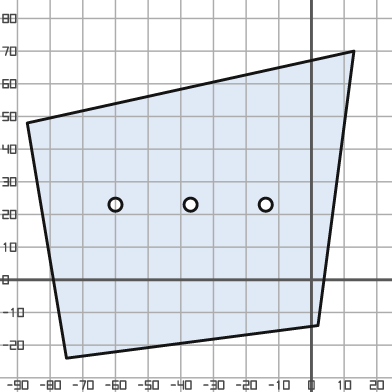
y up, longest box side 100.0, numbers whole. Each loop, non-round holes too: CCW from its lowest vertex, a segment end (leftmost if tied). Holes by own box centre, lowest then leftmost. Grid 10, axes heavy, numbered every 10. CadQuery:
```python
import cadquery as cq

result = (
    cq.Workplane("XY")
    .moveTo(-75.0, -24.0)
    .lineTo(2.0, -14.0)
    .lineTo(13.0, 70.0)
    .lineTo(-87.0, 48.0)
    .close()
    .moveTo(-60.0, 23.0)
    .circle(2.0)
    .moveTo(-37.0, 23.0)
    .circle(2.0)
    .moveTo(-14.0, 23.0)
    .circle(2.0)
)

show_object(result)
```